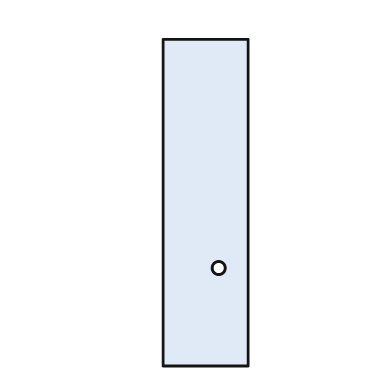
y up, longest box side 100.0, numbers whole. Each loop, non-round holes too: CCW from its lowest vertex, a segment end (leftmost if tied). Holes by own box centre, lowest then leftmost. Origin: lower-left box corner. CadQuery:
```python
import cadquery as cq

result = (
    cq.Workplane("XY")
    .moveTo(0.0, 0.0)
    .lineTo(26.0, 0.0)
    .lineTo(26.0, 100.0)
    .lineTo(0.0, 100.0)
    .close()
    .moveTo(17.0, 30.0)
    .circle(2.0)
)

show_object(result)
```